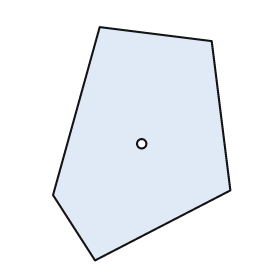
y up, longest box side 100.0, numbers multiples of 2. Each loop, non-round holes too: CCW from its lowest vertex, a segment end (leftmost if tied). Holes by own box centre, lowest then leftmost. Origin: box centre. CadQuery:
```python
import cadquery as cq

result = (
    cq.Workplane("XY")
    .moveTo(-20.0, -50.0)
    .lineTo(38.0, -20.0)
    .lineTo(30.0, 44.0)
    .lineTo(-18.0, 50.0)
    .lineTo(-38.0, -22.0)
    .close()
    .moveTo(0.0, 0.0)
    .circle(2.0)
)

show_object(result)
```